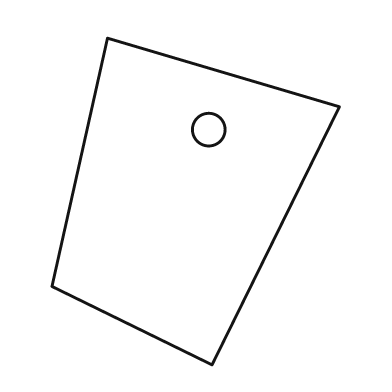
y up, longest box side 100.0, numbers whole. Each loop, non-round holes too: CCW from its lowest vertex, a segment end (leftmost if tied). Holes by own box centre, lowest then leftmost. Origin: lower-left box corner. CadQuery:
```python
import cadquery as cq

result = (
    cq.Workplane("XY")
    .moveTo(49.0, 0.0)
    .lineTo(88.0, 79.0)
    .lineTo(17.0, 100.0)
    .lineTo(0.0, 24.0)
    .close()
    .moveTo(48.0, 72.0)
    .circle(5.0)
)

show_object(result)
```